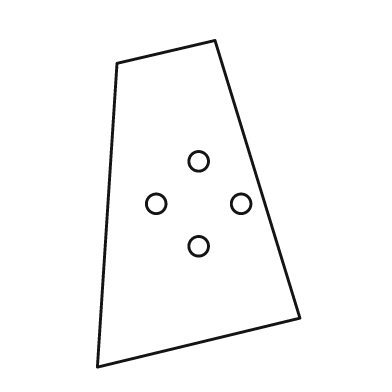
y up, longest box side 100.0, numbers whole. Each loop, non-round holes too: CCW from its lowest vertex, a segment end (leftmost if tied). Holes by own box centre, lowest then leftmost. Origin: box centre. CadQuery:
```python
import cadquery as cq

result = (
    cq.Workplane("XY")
    .moveTo(-31.0, -50.0)
    .lineTo(31.0, -35.0)
    .lineTo(5.0, 50.0)
    .lineTo(-25.0, 43.0)
    .close()
    .moveTo(0.0, -13.0)
    .circle(3.0)
    .moveTo(-13.0, 0.0)
    .circle(3.0)
    .moveTo(13.0, 0.0)
    .circle(3.0)
    .moveTo(0.0, 13.0)
    .circle(3.0)
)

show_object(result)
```